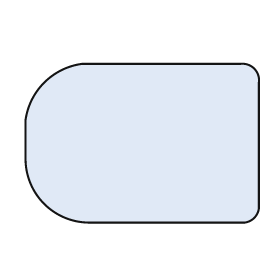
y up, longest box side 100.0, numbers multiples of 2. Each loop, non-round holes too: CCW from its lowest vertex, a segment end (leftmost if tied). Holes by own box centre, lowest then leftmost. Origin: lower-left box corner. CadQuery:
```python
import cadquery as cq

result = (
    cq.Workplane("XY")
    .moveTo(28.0, 0.0)
    .lineTo(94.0, 0.0)
    .threePointArc((98.0, 2.0), (100.0, 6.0))
    .lineTo(100.0, 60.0)
    .threePointArc((98.0, 66.0), (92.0, 68.0))
    .lineTo(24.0, 68.0)
    .threePointArc((8.0, 60.0), (0.0, 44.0))
    .lineTo(0.0, 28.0)
    .threePointArc((8.0, 8.0), (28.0, 0.0))
    .close()
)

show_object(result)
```